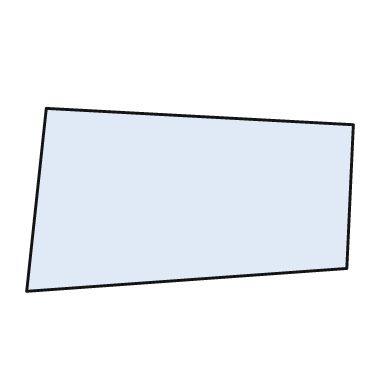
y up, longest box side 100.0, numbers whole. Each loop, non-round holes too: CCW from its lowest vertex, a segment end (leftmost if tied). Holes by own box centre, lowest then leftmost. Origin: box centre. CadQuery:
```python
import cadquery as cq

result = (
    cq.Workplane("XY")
    .moveTo(-50.0, -28.0)
    .lineTo(48.0, -21.0)
    .lineTo(50.0, 23.0)
    .lineTo(-44.0, 28.0)
    .close()
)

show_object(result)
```